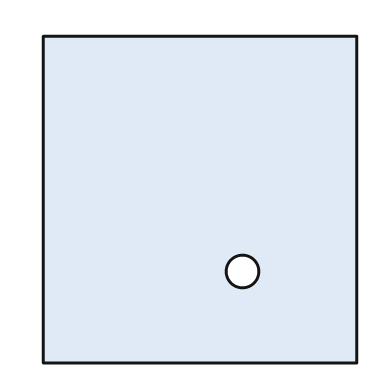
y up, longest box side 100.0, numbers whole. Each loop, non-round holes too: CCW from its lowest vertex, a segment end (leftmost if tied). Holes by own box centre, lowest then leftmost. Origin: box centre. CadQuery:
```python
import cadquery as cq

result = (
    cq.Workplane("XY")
    .moveTo(-48.0, -50.0)
    .lineTo(48.0, -50.0)
    .lineTo(48.0, 50.0)
    .lineTo(-48.0, 50.0)
    .close()
    .moveTo(13.0, -22.0)
    .circle(5.0)
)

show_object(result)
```